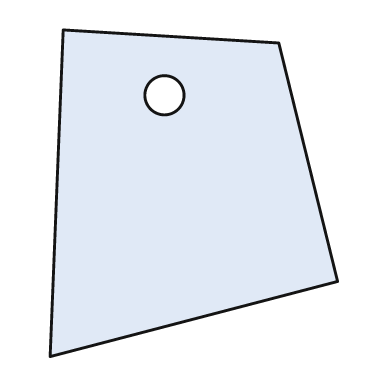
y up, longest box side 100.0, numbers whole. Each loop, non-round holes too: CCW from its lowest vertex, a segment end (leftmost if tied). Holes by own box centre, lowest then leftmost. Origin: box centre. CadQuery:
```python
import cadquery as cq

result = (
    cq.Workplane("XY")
    .moveTo(-44.0, -50.0)
    .lineTo(44.0, -27.0)
    .lineTo(26.0, 46.0)
    .lineTo(-40.0, 50.0)
    .close()
    .moveTo(-9.0, 30.0)
    .circle(6.0)
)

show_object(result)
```